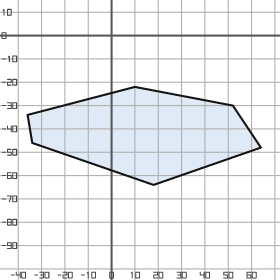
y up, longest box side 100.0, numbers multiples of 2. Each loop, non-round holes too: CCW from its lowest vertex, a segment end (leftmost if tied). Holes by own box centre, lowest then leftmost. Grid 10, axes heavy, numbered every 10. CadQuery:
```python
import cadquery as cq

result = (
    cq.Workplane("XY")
    .moveTo(18.0, -64.0)
    .lineTo(64.0, -48.0)
    .lineTo(52.0, -30.0)
    .lineTo(10.0, -22.0)
    .lineTo(-36.0, -34.0)
    .lineTo(-34.0, -46.0)
    .close()
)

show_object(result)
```